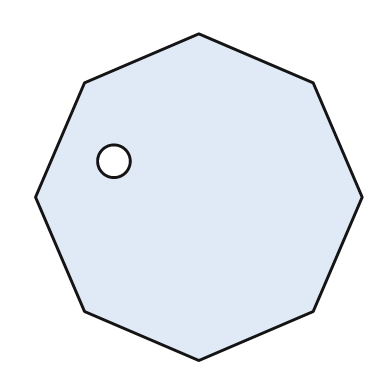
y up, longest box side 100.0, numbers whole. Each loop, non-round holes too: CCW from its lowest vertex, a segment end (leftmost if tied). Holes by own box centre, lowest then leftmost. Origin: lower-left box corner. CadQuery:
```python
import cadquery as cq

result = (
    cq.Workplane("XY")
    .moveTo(50.0, 0.0)
    .lineTo(85.0, 15.0)
    .lineTo(100.0, 50.0)
    .lineTo(85.0, 85.0)
    .lineTo(50.0, 100.0)
    .lineTo(15.0, 85.0)
    .lineTo(0.0, 50.0)
    .lineTo(15.0, 15.0)
    .close()
    .moveTo(24.0, 61.0)
    .circle(5.0)
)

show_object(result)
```